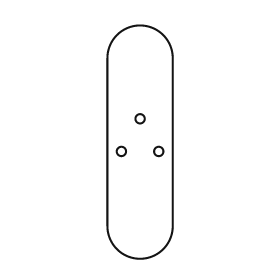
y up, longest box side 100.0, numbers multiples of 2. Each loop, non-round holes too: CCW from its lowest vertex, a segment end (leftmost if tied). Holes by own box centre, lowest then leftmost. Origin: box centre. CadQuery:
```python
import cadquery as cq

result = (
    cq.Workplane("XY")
    .moveTo(-14.0, -36.0)
    .threePointArc((0.0, -50.0), (14.0, -36.0))
    .lineTo(14.0, 36.0)
    .threePointArc((0.0, 50.0), (-14.0, 36.0))
    .close()
    .moveTo(-8.0, -4.0)
    .circle(2.0)
    .moveTo(8.0, -4.0)
    .circle(2.0)
    .moveTo(0.0, 10.0)
    .circle(2.0)
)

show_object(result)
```